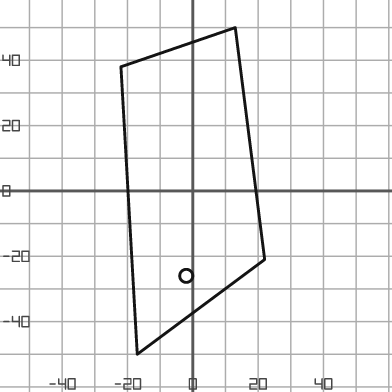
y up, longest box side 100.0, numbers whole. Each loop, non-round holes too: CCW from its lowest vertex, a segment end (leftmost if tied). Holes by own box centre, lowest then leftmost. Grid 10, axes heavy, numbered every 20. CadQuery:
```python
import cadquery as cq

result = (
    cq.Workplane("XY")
    .moveTo(-17.0, -50.0)
    .lineTo(22.0, -21.0)
    .lineTo(13.0, 50.0)
    .lineTo(-22.0, 38.0)
    .close()
    .moveTo(-2.0, -26.0)
    .circle(2.0)
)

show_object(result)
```